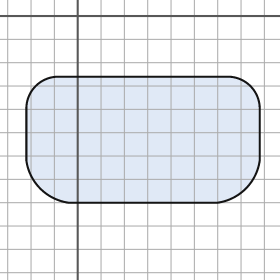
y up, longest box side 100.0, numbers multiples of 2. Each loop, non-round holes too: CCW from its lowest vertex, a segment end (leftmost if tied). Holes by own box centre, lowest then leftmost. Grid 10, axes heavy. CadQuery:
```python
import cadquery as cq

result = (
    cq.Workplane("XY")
    .moveTo(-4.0, -80.0)
    .lineTo(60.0, -80.0)
    .threePointArc((72.0, -74.0), (78.0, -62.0))
    .lineTo(78.0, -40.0)
    .threePointArc((74.0, -30.0), (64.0, -26.0))
    .lineTo(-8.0, -26.0)
    .threePointArc((-18.0, -30.0), (-22.0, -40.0))
    .lineTo(-22.0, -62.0)
    .threePointArc((-16.0, -74.0), (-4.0, -80.0))
    .close()
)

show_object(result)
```